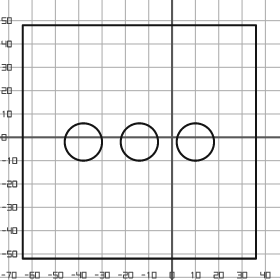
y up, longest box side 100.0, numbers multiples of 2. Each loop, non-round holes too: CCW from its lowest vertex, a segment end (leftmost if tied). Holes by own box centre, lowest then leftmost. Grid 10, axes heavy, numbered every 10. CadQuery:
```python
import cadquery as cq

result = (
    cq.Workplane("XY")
    .moveTo(-64.0, -52.0)
    .lineTo(36.0, -52.0)
    .lineTo(36.0, 48.0)
    .lineTo(-64.0, 48.0)
    .close()
    .moveTo(-38.0, -2.0)
    .circle(8.0)
    .moveTo(-14.0, -2.0)
    .circle(8.0)
    .moveTo(10.0, -2.0)
    .circle(8.0)
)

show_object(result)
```